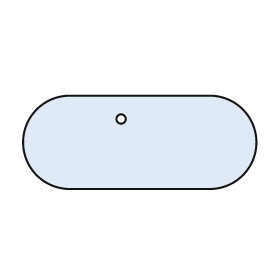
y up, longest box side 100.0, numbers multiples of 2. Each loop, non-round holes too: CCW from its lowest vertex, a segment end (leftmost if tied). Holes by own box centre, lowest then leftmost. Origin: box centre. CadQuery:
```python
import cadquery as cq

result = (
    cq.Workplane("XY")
    .moveTo(-30.0, -20.0)
    .lineTo(30.0, -20.0)
    .threePointArc((50.0, 0.0), (30.0, 20.0))
    .lineTo(-30.0, 20.0)
    .threePointArc((-50.0, 0.0), (-30.0, -20.0))
    .close()
    .moveTo(-8.0, 10.0)
    .circle(2.0)
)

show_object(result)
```